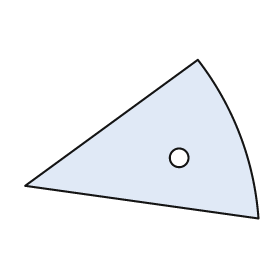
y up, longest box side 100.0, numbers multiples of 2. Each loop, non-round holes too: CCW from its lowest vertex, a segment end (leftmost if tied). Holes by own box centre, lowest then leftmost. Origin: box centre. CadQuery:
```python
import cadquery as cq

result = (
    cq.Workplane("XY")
    .moveTo(50.0, -34.0)
    .threePointArc((42.0, 2.0), (24.0, 34.0))
    .lineTo(-50.0, -20.0)
    .close()
    .moveTo(16.0, -8.0)
    .circle(4.0)
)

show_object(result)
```